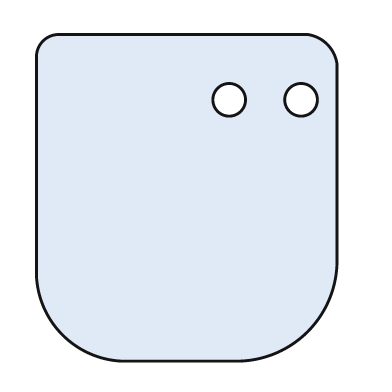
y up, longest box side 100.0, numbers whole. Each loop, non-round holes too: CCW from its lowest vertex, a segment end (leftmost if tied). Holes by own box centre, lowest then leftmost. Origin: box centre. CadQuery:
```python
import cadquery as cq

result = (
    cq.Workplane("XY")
    .moveTo(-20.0, -50.0)
    .lineTo(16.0, -50.0)
    .threePointArc((37.0, -41.0), (46.0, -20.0))
    .lineTo(46.0, 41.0)
    .threePointArc((43.0, 47.0), (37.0, 50.0))
    .lineTo(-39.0, 50.0)
    .threePointArc((-44.0, 48.0), (-46.0, 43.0))
    .lineTo(-46.0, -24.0)
    .threePointArc((-38.0, -42.0), (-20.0, -50.0))
    .close()
    .moveTo(13.0, 30.0)
    .circle(5.0)
    .moveTo(35.0, 30.0)
    .circle(5.0)
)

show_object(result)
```